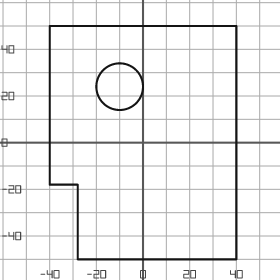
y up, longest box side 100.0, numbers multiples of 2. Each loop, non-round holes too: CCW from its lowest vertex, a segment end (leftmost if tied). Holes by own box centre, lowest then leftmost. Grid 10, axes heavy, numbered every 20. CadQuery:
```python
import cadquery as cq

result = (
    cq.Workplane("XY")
    .moveTo(-28.0, -50.0)
    .lineTo(40.0, -50.0)
    .lineTo(40.0, 50.0)
    .lineTo(-40.0, 50.0)
    .lineTo(-40.0, -18.0)
    .lineTo(-28.0, -18.0)
    .close()
    .moveTo(-10.0, 24.0)
    .circle(10.0)
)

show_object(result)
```